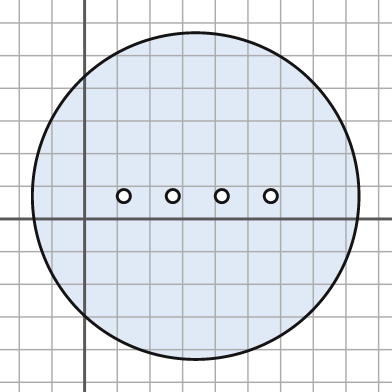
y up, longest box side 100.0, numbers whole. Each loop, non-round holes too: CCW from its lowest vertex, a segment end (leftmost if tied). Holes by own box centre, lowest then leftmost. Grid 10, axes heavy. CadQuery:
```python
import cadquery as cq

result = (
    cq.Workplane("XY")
    .moveTo(34.0, 7.0)
    .circle(50.0)
    .moveTo(12.0, 7.0)
    .circle(2.0)
    .moveTo(27.0, 7.0)
    .circle(2.0)
    .moveTo(42.0, 7.0)
    .circle(2.0)
    .moveTo(57.0, 7.0)
    .circle(2.0)
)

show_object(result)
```